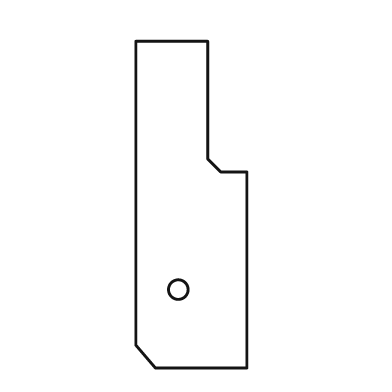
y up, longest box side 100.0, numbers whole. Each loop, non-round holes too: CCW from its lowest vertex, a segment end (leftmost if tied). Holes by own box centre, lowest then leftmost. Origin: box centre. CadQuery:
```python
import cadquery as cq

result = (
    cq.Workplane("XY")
    .moveTo(-11.0, -50.0)
    .lineTo(17.0, -50.0)
    .lineTo(17.0, 10.0)
    .lineTo(9.0, 10.0)
    .lineTo(5.0, 14.0)
    .lineTo(5.0, 50.0)
    .lineTo(-17.0, 50.0)
    .lineTo(-17.0, -43.0)
    .close()
    .moveTo(-4.0, -26.0)
    .circle(3.0)
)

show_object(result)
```